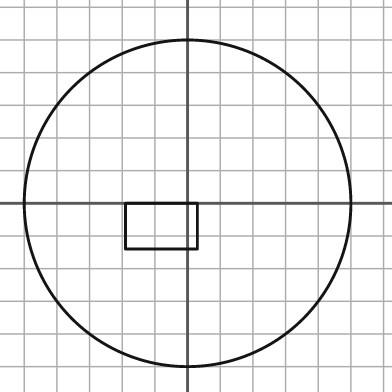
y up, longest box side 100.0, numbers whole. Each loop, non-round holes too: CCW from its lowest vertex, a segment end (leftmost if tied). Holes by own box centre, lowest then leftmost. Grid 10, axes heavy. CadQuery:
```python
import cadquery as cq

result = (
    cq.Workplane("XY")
    .moveTo(0.0, 0.0)
    .circle(50.0)
    .moveTo(-19.0, -14.0)
    .lineTo(3.0, -14.0)
    .lineTo(3.0, 0.0)
    .lineTo(-19.0, 0.0)
    .close()
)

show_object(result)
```